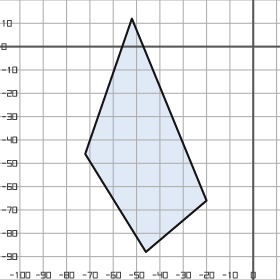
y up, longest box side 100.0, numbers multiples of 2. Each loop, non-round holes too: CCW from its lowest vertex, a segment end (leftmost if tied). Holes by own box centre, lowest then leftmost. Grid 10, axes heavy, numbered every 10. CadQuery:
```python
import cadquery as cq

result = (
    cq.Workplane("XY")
    .moveTo(-46.0, -88.0)
    .lineTo(-20.0, -66.0)
    .lineTo(-52.0, 12.0)
    .lineTo(-72.0, -46.0)
    .close()
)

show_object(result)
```